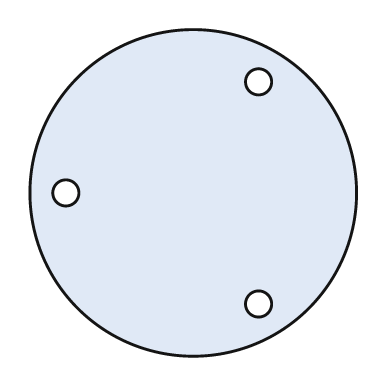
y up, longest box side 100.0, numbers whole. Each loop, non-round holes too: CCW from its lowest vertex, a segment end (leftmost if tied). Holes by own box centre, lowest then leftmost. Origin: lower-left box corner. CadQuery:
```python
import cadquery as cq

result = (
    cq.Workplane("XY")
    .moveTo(50.0, 50.0)
    .circle(50.0)
    .moveTo(70.0, 16.0)
    .circle(4.0)
    .moveTo(11.0, 50.0)
    .circle(4.0)
    .moveTo(70.0, 84.0)
    .circle(4.0)
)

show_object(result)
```